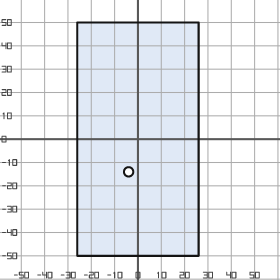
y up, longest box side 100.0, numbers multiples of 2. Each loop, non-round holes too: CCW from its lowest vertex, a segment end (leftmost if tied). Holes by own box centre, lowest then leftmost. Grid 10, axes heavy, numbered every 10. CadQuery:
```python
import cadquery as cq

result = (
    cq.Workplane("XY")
    .moveTo(-26.0, -50.0)
    .lineTo(26.0, -50.0)
    .lineTo(26.0, 50.0)
    .lineTo(-26.0, 50.0)
    .close()
    .moveTo(-4.0, -14.0)
    .circle(2.0)
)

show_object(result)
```